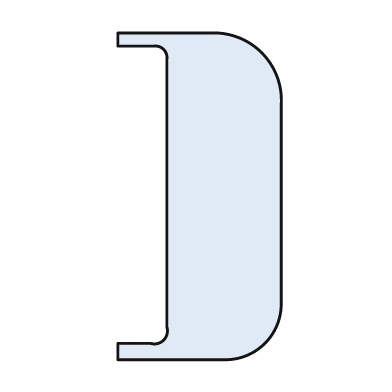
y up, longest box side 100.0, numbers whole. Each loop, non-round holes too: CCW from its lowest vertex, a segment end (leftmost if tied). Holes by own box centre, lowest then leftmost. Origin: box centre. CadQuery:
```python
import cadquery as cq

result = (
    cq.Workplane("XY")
    .moveTo(-25.0, -50.0)
    .lineTo(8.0, -50.0)
    .threePointArc((20.0, -45.0), (25.0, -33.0))
    .lineTo(25.0, 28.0)
    .threePointArc((19.0, 44.0), (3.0, 50.0))
    .lineTo(-25.0, 50.0)
    .lineTo(-25.0, 46.0)
    .lineTo(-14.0, 46.0)
    .threePointArc((-11.0, 45.0), (-10.0, 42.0))
    .lineTo(-10.0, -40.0)
    .threePointArc((-11.0, -44.0), (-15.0, -45.0))
    .lineTo(-25.0, -45.0)
    .close()
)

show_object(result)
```